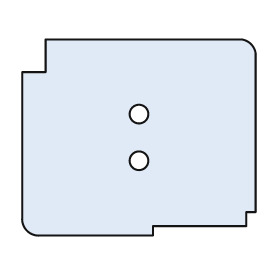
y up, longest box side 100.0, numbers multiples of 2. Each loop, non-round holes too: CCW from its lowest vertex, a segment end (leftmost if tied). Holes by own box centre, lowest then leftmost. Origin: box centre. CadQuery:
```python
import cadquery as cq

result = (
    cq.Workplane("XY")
    .moveTo(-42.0, -42.0)
    .lineTo(6.0, -42.0)
    .lineTo(6.0, -38.0)
    .lineTo(46.0, -38.0)
    .lineTo(46.0, -32.0)
    .lineTo(50.0, -32.0)
    .lineTo(50.0, 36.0)
    .threePointArc((48.0, 40.0), (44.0, 42.0))
    .lineTo(-40.0, 42.0)
    .lineTo(-40.0, 28.0)
    .lineTo(-50.0, 28.0)
    .lineTo(-50.0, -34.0)
    .threePointArc((-48.0, -40.0), (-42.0, -42.0))
    .close()
    .moveTo(0.0, -10.0)
    .circle(4.0)
    .moveTo(0.0, 10.0)
    .circle(4.0)
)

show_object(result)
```